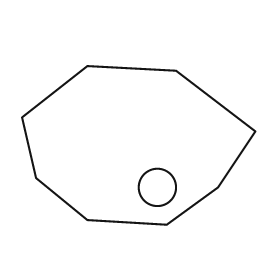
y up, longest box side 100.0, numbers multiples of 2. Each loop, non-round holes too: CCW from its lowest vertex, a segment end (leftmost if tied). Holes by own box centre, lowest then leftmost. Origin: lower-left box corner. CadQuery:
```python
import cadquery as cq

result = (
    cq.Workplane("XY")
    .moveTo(62.0, 0.0)
    .lineTo(84.0, 16.0)
    .lineTo(100.0, 40.0)
    .lineTo(66.0, 66.0)
    .lineTo(28.0, 68.0)
    .lineTo(0.0, 46.0)
    .lineTo(6.0, 20.0)
    .lineTo(28.0, 2.0)
    .close()
    .moveTo(58.0, 16.0)
    .circle(8.0)
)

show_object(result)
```